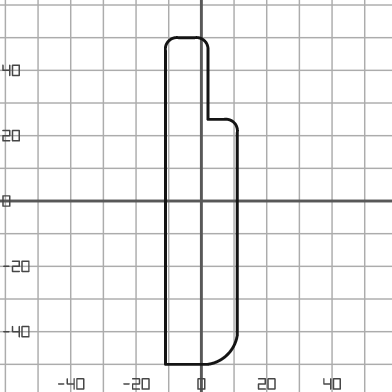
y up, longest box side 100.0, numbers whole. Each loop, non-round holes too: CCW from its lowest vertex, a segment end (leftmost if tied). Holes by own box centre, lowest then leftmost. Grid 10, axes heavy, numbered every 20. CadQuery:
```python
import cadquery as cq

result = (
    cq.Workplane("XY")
    .moveTo(-11.0, -50.0)
    .lineTo(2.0, -50.0)
    .threePointArc((8.0, -47.0), (11.0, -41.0))
    .lineTo(11.0, 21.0)
    .threePointArc((10.0, 24.0), (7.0, 25.0))
    .lineTo(2.0, 25.0)
    .lineTo(2.0, 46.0)
    .threePointArc((1.0, 49.0), (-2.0, 50.0))
    .lineTo(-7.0, 50.0)
    .threePointArc((-10.0, 49.0), (-11.0, 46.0))
    .close()
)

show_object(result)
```